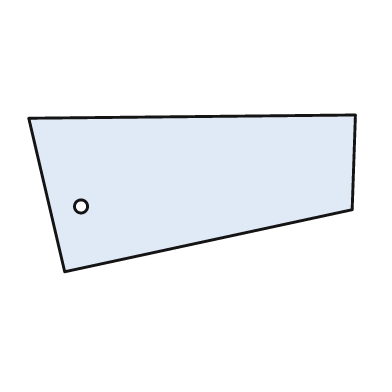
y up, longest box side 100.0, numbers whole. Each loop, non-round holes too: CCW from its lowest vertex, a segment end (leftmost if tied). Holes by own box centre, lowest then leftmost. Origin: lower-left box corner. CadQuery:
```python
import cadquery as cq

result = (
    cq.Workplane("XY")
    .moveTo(11.0, 0.0)
    .lineTo(99.0, 19.0)
    .lineTo(100.0, 48.0)
    .lineTo(0.0, 47.0)
    .close()
    .moveTo(16.0, 20.0)
    .circle(2.0)
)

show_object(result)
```